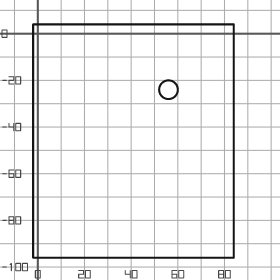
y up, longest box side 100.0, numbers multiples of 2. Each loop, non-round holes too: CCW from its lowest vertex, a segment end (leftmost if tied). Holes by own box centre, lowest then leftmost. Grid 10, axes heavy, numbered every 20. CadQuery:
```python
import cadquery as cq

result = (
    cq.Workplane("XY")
    .moveTo(-2.0, -96.0)
    .lineTo(84.0, -96.0)
    .lineTo(84.0, 4.0)
    .lineTo(-2.0, 4.0)
    .close()
    .moveTo(56.0, -24.0)
    .circle(4.0)
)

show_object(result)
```